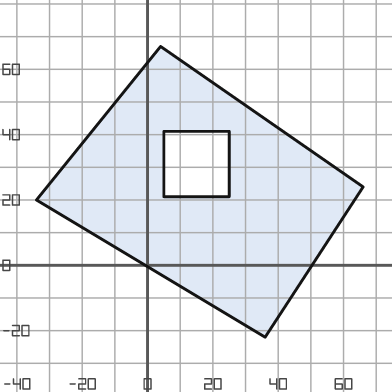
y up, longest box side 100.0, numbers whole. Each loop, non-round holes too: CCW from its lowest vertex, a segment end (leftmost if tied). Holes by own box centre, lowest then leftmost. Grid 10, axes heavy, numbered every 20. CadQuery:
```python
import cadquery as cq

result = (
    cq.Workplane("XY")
    .moveTo(36.0, -22.0)
    .lineTo(66.0, 24.0)
    .lineTo(4.0, 67.0)
    .lineTo(-34.0, 20.0)
    .close()
    .moveTo(5.0, 21.0)
    .lineTo(25.0, 21.0)
    .lineTo(25.0, 41.0)
    .lineTo(5.0, 41.0)
    .close()
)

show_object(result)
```